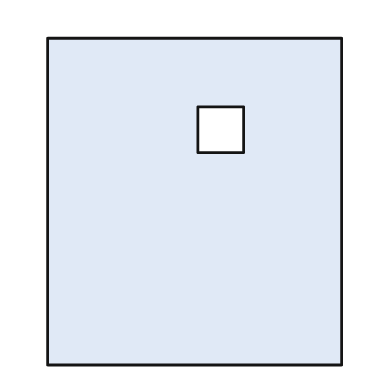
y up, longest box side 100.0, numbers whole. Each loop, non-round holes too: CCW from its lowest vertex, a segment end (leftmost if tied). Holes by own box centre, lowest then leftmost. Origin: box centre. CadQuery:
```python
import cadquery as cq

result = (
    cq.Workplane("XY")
    .moveTo(-45.0, -50.0)
    .lineTo(45.0, -50.0)
    .lineTo(45.0, 50.0)
    .lineTo(-45.0, 50.0)
    .close()
    .moveTo(1.0, 15.0)
    .lineTo(15.0, 15.0)
    .lineTo(15.0, 29.0)
    .lineTo(1.0, 29.0)
    .close()
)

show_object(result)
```